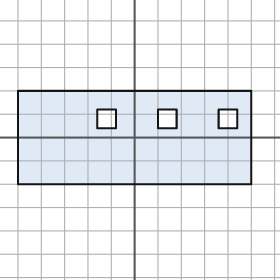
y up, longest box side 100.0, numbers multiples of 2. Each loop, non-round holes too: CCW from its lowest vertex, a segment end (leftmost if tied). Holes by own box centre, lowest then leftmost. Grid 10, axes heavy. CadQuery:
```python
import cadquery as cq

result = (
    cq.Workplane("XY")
    .moveTo(-50.0, -20.0)
    .lineTo(50.0, -20.0)
    .lineTo(50.0, 20.0)
    .lineTo(-50.0, 20.0)
    .close()
    .moveTo(-16.0, 4.0)
    .lineTo(-8.0, 4.0)
    .lineTo(-8.0, 12.0)
    .lineTo(-16.0, 12.0)
    .close()
    .moveTo(10.0, 4.0)
    .lineTo(18.0, 4.0)
    .lineTo(18.0, 12.0)
    .lineTo(10.0, 12.0)
    .close()
    .moveTo(36.0, 4.0)
    .lineTo(44.0, 4.0)
    .lineTo(44.0, 12.0)
    .lineTo(36.0, 12.0)
    .close()
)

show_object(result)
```